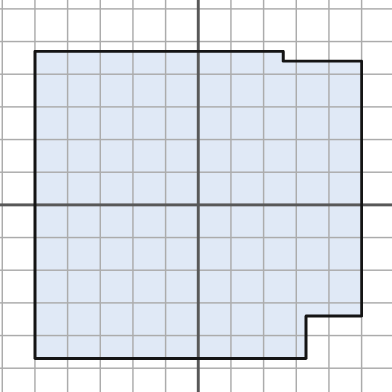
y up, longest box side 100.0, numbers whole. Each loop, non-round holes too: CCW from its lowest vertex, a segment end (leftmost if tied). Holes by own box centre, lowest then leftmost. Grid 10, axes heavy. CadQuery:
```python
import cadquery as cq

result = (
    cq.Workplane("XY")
    .moveTo(-50.0, -47.0)
    .lineTo(33.0, -47.0)
    .lineTo(33.0, -34.0)
    .lineTo(50.0, -34.0)
    .lineTo(50.0, 44.0)
    .lineTo(26.0, 44.0)
    .lineTo(26.0, 47.0)
    .lineTo(-50.0, 47.0)
    .close()
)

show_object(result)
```